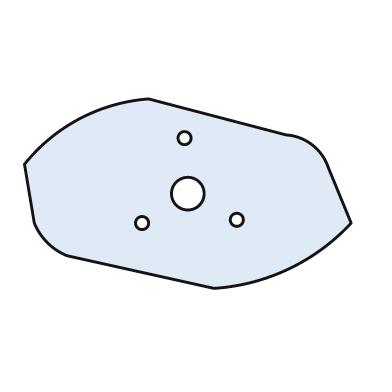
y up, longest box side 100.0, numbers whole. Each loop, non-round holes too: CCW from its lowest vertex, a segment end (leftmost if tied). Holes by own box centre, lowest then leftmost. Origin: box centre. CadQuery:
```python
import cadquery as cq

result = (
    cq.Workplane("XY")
    .moveTo(8.0, -29.0)
    .threePointArc((31.0, -23.0), (50.0, -9.0))
    .lineTo(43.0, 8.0)
    .threePointArc((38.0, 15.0), (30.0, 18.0))
    .lineTo(-12.0, 29.0)
    .threePointArc((-33.0, 23.0), (-50.0, 9.0))
    .lineTo(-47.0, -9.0)
    .threePointArc((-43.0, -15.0), (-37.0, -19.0))
    .close()
    .moveTo(-14.0, -9.0)
    .circle(2.0)
    .moveTo(15.0, -8.0)
    .circle(2.0)
    .moveTo(0.0, 0.0)
    .circle(5.0)
    .moveTo(-1.0, 17.0)
    .circle(2.0)
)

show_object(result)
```